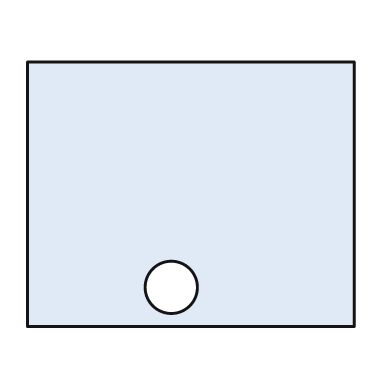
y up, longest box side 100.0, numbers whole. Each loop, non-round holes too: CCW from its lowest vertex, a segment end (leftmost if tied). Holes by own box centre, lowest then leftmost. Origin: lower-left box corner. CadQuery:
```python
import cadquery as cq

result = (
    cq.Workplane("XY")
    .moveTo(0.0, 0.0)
    .lineTo(100.0, 0.0)
    .lineTo(100.0, 81.0)
    .lineTo(0.0, 81.0)
    .close()
    .moveTo(44.0, 12.0)
    .circle(8.0)
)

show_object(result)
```